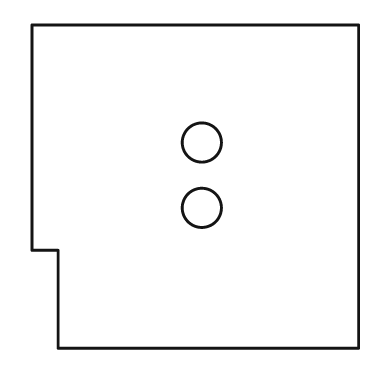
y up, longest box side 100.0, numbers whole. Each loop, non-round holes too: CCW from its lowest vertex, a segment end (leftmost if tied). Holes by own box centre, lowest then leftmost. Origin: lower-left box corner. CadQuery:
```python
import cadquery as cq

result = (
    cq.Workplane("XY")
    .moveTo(8.0, 0.0)
    .lineTo(100.0, 0.0)
    .lineTo(100.0, 99.0)
    .lineTo(0.0, 99.0)
    .lineTo(0.0, 30.0)
    .lineTo(8.0, 30.0)
    .close()
    .moveTo(52.0, 43.0)
    .circle(6.0)
    .moveTo(52.0, 63.0)
    .circle(6.0)
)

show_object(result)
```